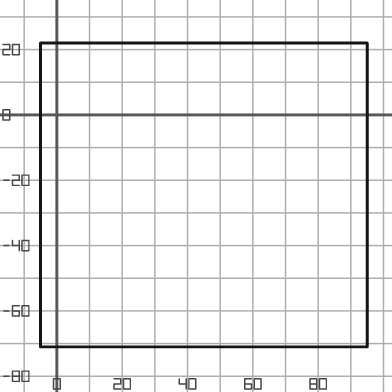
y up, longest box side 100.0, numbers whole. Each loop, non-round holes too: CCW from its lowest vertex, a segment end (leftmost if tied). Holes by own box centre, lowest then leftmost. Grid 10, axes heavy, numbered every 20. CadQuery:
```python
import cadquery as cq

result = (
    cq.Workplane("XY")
    .moveTo(-5.0, -71.0)
    .lineTo(95.0, -71.0)
    .lineTo(95.0, 22.0)
    .lineTo(-5.0, 22.0)
    .close()
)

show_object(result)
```